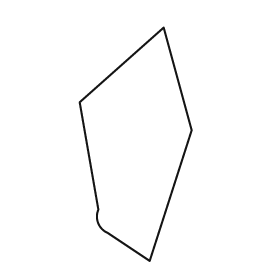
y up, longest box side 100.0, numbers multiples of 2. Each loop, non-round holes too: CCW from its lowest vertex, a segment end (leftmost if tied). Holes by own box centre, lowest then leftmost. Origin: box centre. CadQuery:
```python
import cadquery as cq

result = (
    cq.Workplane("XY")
    .moveTo(6.0, -50.0)
    .lineTo(24.0, 6.0)
    .lineTo(12.0, 50.0)
    .lineTo(-24.0, 18.0)
    .lineTo(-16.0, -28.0)
    .threePointArc((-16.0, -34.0), (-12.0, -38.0))
    .close()
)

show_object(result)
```